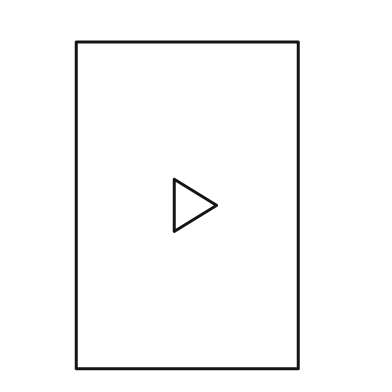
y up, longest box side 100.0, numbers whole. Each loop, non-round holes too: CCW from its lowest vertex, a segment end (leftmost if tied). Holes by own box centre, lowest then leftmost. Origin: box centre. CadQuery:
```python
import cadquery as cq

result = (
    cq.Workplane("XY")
    .moveTo(-34.0, -50.0)
    .lineTo(34.0, -50.0)
    .lineTo(34.0, 50.0)
    .lineTo(-34.0, 50.0)
    .close()
    .moveTo(-4.0, -8.0)
    .lineTo(9.0, 0.0)
    .lineTo(-4.0, 8.0)
    .close()
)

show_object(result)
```